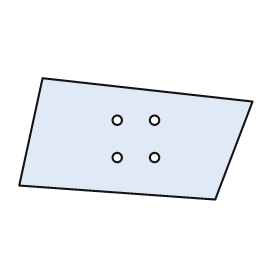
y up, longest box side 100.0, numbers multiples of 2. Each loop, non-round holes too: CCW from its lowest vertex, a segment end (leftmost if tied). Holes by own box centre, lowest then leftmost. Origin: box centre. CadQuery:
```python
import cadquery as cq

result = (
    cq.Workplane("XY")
    .moveTo(34.0, -26.0)
    .lineTo(50.0, 16.0)
    .lineTo(-40.0, 26.0)
    .lineTo(-50.0, -20.0)
    .close()
    .moveTo(-8.0, -8.0)
    .circle(2.0)
    .moveTo(8.0, -8.0)
    .circle(2.0)
    .moveTo(-8.0, 8.0)
    .circle(2.0)
    .moveTo(8.0, 8.0)
    .circle(2.0)
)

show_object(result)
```